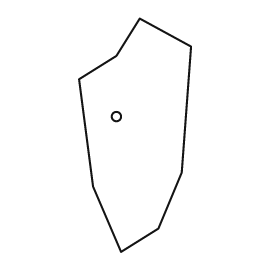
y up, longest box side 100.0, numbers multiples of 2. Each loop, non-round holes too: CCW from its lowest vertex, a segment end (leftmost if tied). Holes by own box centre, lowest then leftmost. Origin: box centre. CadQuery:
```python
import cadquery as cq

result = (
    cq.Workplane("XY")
    .moveTo(-6.0, -50.0)
    .lineTo(10.0, -40.0)
    .lineTo(20.0, -16.0)
    .lineTo(24.0, 38.0)
    .lineTo(2.0, 50.0)
    .lineTo(-8.0, 34.0)
    .lineTo(-24.0, 24.0)
    .lineTo(-18.0, -22.0)
    .close()
    .moveTo(-8.0, 8.0)
    .circle(2.0)
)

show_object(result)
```